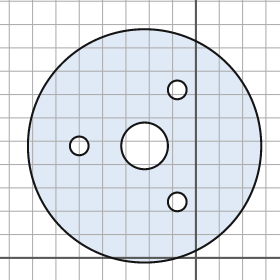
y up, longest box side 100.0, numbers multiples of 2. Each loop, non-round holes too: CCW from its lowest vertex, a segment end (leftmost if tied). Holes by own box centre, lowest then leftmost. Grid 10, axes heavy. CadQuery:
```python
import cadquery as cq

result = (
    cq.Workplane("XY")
    .moveTo(-22.0, 48.0)
    .circle(50.0)
    .moveTo(-8.0, 24.0)
    .circle(4.0)
    .moveTo(-50.0, 48.0)
    .circle(4.0)
    .moveTo(-22.0, 48.0)
    .circle(10.0)
    .moveTo(-8.0, 72.0)
    .circle(4.0)
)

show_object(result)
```